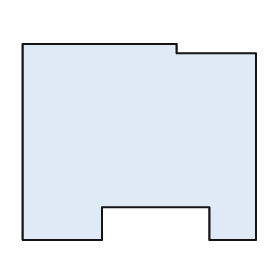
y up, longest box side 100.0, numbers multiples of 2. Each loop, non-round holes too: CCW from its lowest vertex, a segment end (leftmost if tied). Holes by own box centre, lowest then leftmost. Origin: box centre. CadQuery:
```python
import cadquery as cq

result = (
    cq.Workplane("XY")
    .moveTo(-50.0, -42.0)
    .lineTo(-16.0, -42.0)
    .lineTo(-16.0, -28.0)
    .lineTo(30.0, -28.0)
    .lineTo(30.0, -42.0)
    .lineTo(50.0, -42.0)
    .lineTo(50.0, 38.0)
    .lineTo(16.0, 38.0)
    .lineTo(16.0, 42.0)
    .lineTo(-50.0, 42.0)
    .close()
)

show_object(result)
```